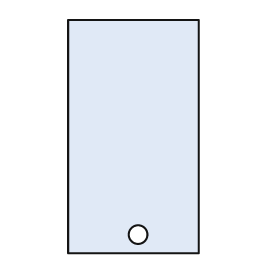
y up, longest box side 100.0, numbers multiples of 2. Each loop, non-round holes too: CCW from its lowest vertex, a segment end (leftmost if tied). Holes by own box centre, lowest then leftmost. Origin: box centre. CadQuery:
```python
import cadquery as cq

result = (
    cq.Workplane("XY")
    .moveTo(-28.0, -50.0)
    .lineTo(28.0, -50.0)
    .lineTo(28.0, 50.0)
    .lineTo(-28.0, 50.0)
    .close()
    .moveTo(2.0, -42.0)
    .circle(4.0)
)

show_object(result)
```